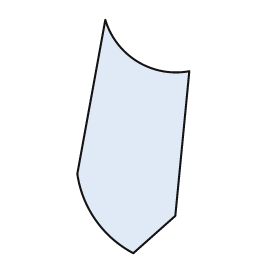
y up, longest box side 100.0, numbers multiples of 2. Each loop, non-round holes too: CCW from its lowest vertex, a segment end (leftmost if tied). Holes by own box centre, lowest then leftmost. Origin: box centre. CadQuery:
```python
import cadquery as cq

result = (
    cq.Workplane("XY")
    .moveTo(0.0, -50.0)
    .lineTo(18.0, -34.0)
    .lineTo(24.0, 28.0)
    .threePointArc((2.0, 32.0), (-12.0, 50.0))
    .lineTo(-24.0, -16.0)
    .threePointArc((-16.0, -36.0), (0.0, -50.0))
    .close()
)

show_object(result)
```